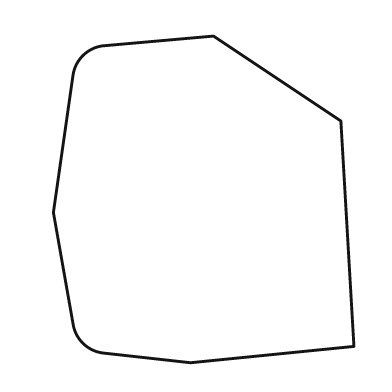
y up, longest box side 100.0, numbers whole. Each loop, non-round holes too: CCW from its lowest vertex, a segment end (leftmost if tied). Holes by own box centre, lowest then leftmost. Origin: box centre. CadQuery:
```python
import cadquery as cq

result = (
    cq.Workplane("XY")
    .moveTo(-4.0, -50.0)
    .lineTo(46.0, -45.0)
    .lineTo(42.0, 24.0)
    .lineTo(3.0, 50.0)
    .lineTo(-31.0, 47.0)
    .threePointArc((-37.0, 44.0), (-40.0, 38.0))
    .lineTo(-46.0, -4.0)
    .lineTo(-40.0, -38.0)
    .threePointArc((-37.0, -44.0), (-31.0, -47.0))
    .close()
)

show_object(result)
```